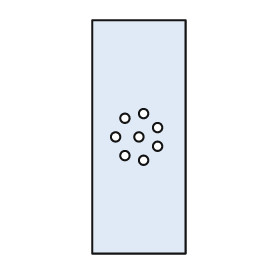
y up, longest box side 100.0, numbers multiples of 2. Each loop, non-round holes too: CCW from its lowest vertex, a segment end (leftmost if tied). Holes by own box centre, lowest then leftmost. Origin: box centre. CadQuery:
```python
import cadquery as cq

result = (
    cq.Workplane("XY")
    .moveTo(-20.0, -50.0)
    .lineTo(20.0, -50.0)
    .lineTo(20.0, 50.0)
    .lineTo(-20.0, 50.0)
    .close()
    .moveTo(2.0, -10.0)
    .circle(2.0)
    .moveTo(-6.0, -8.0)
    .circle(2.0)
    .moveTo(8.0, -4.0)
    .circle(2.0)
    .moveTo(-10.0, 0.0)
    .circle(2.0)
    .moveTo(0.0, 0.0)
    .circle(2.0)
    .moveTo(8.0, 4.0)
    .circle(2.0)
    .moveTo(-6.0, 8.0)
    .circle(2.0)
    .moveTo(2.0, 10.0)
    .circle(2.0)
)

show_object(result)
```